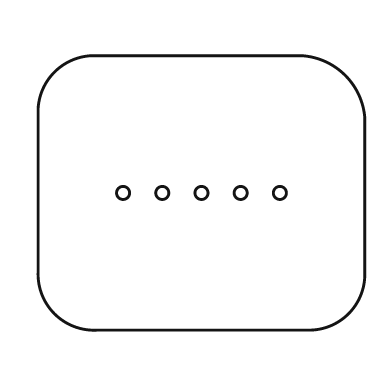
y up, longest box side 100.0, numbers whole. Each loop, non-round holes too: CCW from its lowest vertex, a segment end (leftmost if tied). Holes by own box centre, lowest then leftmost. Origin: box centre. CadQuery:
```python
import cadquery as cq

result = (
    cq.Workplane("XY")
    .moveTo(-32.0, -42.0)
    .lineTo(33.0, -42.0)
    .threePointArc((45.0, -37.0), (50.0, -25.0))
    .lineTo(50.0, 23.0)
    .threePointArc((44.0, 36.0), (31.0, 42.0))
    .lineTo(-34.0, 42.0)
    .threePointArc((-45.0, 37.0), (-50.0, 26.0))
    .lineTo(-50.0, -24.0)
    .threePointArc((-45.0, -37.0), (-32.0, -42.0))
    .close()
    .moveTo(-24.0, 0.0)
    .circle(2.0)
    .moveTo(-12.0, 0.0)
    .circle(2.0)
    .moveTo(0.0, 0.0)
    .circle(2.0)
    .moveTo(12.0, 0.0)
    .circle(2.0)
    .moveTo(24.0, 0.0)
    .circle(2.0)
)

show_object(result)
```